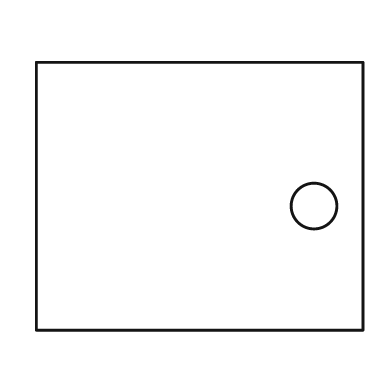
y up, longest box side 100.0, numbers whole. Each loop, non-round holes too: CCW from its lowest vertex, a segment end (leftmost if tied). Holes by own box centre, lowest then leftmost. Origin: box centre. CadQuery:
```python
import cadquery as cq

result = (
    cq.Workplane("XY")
    .moveTo(-50.0, -41.0)
    .lineTo(50.0, -41.0)
    .lineTo(50.0, 41.0)
    .lineTo(-50.0, 41.0)
    .close()
    .moveTo(35.0, -3.0)
    .circle(7.0)
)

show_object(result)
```